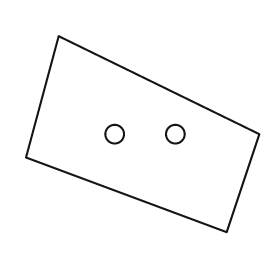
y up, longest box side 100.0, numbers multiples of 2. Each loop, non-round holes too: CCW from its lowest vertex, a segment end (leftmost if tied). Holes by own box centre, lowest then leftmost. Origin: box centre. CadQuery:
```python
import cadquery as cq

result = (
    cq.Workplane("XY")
    .moveTo(36.0, -42.0)
    .lineTo(50.0, 0.0)
    .lineTo(-36.0, 42.0)
    .lineTo(-50.0, -10.0)
    .close()
    .moveTo(-12.0, 0.0)
    .circle(4.0)
    .moveTo(14.0, 0.0)
    .circle(4.0)
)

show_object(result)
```